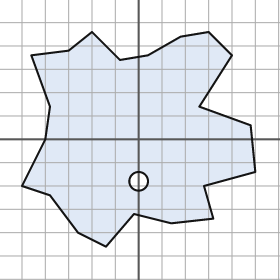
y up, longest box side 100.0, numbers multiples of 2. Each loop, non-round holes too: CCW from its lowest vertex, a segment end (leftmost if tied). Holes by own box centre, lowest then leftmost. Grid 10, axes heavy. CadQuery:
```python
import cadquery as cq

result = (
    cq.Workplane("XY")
    .moveTo(-14.0, -46.0)
    .lineTo(-2.0, -32.0)
    .lineTo(14.0, -36.0)
    .lineTo(32.0, -34.0)
    .lineTo(28.0, -20.0)
    .lineTo(50.0, -14.0)
    .lineTo(48.0, 6.0)
    .lineTo(26.0, 14.0)
    .lineTo(40.0, 36.0)
    .lineTo(30.0, 46.0)
    .lineTo(18.0, 44.0)
    .lineTo(4.0, 36.0)
    .lineTo(-8.0, 34.0)
    .lineTo(-20.0, 46.0)
    .lineTo(-30.0, 38.0)
    .lineTo(-46.0, 36.0)
    .lineTo(-38.0, 14.0)
    .lineTo(-40.0, 0.0)
    .lineTo(-50.0, -20.0)
    .lineTo(-38.0, -24.0)
    .lineTo(-26.0, -40.0)
    .close()
    .moveTo(0.0, -18.0)
    .circle(4.0)
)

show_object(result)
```